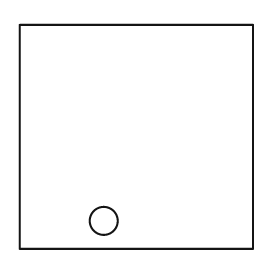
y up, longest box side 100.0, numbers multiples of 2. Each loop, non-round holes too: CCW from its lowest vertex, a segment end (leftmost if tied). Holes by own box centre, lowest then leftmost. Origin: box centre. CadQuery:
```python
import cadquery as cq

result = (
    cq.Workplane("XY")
    .moveTo(-50.0, -48.0)
    .lineTo(50.0, -48.0)
    .lineTo(50.0, 48.0)
    .lineTo(-50.0, 48.0)
    .close()
    .moveTo(-14.0, -36.0)
    .circle(6.0)
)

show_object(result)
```